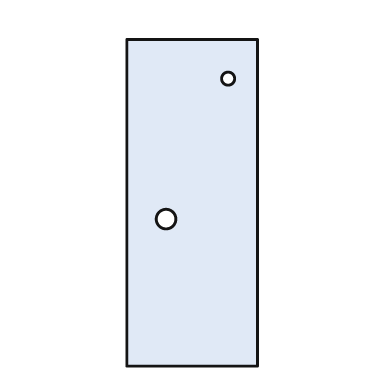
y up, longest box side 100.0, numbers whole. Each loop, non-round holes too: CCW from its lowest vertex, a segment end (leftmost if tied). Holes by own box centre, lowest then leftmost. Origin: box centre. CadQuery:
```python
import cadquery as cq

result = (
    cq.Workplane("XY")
    .moveTo(-20.0, -50.0)
    .lineTo(20.0, -50.0)
    .lineTo(20.0, 50.0)
    .lineTo(-20.0, 50.0)
    .close()
    .moveTo(-8.0, -5.0)
    .circle(3.0)
    .moveTo(11.0, 38.0)
    .circle(2.0)
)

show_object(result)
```